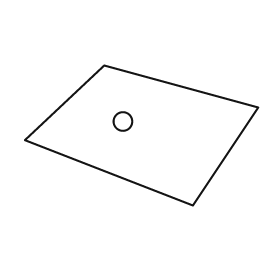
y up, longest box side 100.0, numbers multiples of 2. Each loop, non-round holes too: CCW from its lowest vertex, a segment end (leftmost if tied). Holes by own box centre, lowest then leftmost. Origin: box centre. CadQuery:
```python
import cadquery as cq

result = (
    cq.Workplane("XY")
    .moveTo(22.0, -30.0)
    .lineTo(50.0, 12.0)
    .lineTo(-16.0, 30.0)
    .lineTo(-50.0, -2.0)
    .close()
    .moveTo(-8.0, 6.0)
    .circle(4.0)
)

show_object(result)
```